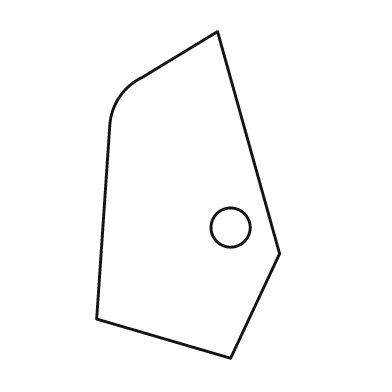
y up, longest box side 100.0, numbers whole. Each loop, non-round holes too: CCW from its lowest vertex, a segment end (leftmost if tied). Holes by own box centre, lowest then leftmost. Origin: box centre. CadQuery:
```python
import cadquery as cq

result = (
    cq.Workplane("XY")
    .moveTo(13.0, -50.0)
    .lineTo(28.0, -18.0)
    .lineTo(9.0, 50.0)
    .lineTo(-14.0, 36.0)
    .threePointArc((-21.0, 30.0), (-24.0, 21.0))
    .lineTo(-28.0, -38.0)
    .close()
    .moveTo(13.0, -10.0)
    .circle(6.0)
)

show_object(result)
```